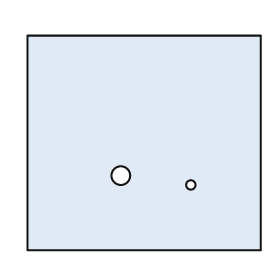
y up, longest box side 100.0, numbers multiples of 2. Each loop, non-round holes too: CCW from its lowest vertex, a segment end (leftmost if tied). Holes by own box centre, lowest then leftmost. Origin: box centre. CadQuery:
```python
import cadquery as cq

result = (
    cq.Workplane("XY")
    .moveTo(-50.0, -46.0)
    .lineTo(50.0, -46.0)
    .lineTo(50.0, 46.0)
    .lineTo(-50.0, 46.0)
    .close()
    .moveTo(20.0, -18.0)
    .circle(2.0)
    .moveTo(-10.0, -14.0)
    .circle(4.0)
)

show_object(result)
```